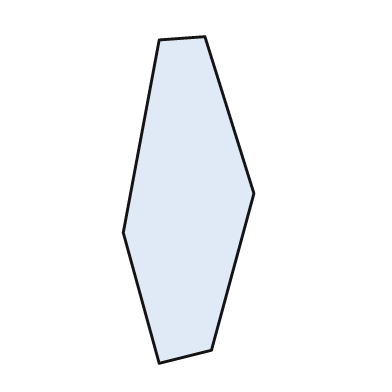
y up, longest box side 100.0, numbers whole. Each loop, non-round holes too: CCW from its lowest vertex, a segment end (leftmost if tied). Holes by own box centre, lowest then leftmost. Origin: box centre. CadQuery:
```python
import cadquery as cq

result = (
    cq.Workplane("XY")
    .moveTo(-9.0, -50.0)
    .lineTo(7.0, -46.0)
    .lineTo(20.0, 2.0)
    .lineTo(5.0, 50.0)
    .lineTo(-9.0, 49.0)
    .lineTo(-20.0, -10.0)
    .close()
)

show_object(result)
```